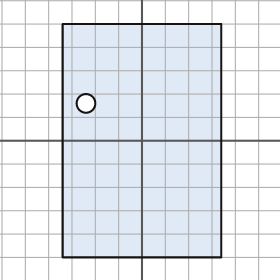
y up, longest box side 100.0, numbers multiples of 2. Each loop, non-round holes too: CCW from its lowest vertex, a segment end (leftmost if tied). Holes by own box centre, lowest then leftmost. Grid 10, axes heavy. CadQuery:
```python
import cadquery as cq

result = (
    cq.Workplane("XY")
    .moveTo(-34.0, -50.0)
    .lineTo(34.0, -50.0)
    .lineTo(34.0, 50.0)
    .lineTo(-34.0, 50.0)
    .close()
    .moveTo(-24.0, 16.0)
    .circle(4.0)
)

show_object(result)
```